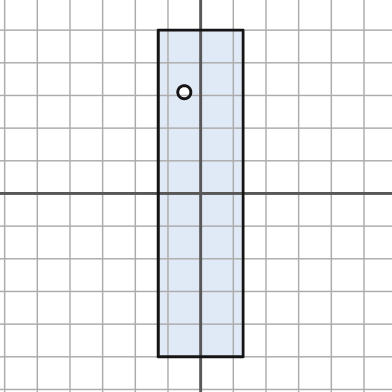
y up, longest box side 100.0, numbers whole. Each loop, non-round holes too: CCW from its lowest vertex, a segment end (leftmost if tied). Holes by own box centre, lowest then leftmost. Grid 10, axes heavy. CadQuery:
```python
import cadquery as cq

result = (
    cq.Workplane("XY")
    .moveTo(-13.0, -50.0)
    .lineTo(13.0, -50.0)
    .lineTo(13.0, 50.0)
    .lineTo(-13.0, 50.0)
    .close()
    .moveTo(-5.0, 31.0)
    .circle(2.0)
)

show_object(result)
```